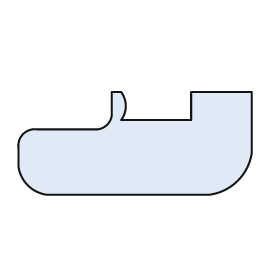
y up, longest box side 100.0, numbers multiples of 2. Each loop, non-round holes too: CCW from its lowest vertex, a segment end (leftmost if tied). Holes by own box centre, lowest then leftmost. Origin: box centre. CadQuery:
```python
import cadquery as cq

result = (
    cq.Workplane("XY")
    .moveTo(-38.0, -22.0)
    .lineTo(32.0, -22.0)
    .threePointArc((44.0, -16.0), (50.0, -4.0))
    .lineTo(50.0, 22.0)
    .lineTo(24.0, 22.0)
    .lineTo(24.0, 10.0)
    .lineTo(-6.0, 10.0)
    .threePointArc((-4.0, 16.0), (-6.0, 22.0))
    .lineTo(-10.0, 22.0)
    .lineTo(-10.0, 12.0)
    .threePointArc((-12.0, 8.0), (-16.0, 6.0))
    .lineTo(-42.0, 6.0)
    .threePointArc((-48.0, 4.0), (-50.0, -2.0))
    .lineTo(-50.0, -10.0)
    .threePointArc((-46.0, -18.0), (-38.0, -22.0))
    .close()
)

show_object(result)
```